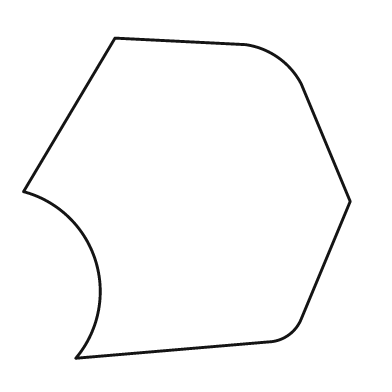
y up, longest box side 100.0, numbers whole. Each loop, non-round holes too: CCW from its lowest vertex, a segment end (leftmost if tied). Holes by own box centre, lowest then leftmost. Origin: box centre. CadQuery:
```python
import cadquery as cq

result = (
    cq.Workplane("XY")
    .moveTo(-34.0, -49.0)
    .lineTo(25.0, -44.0)
    .threePointArc((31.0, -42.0), (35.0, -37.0))
    .lineTo(50.0, -1.0)
    .lineTo(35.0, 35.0)
    .threePointArc((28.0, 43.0), (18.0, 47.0))
    .lineTo(-22.0, 49.0)
    .lineTo(-50.0, 2.0)
    .threePointArc((-28.0, -19.0), (-34.0, -49.0))
    .close()
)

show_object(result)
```